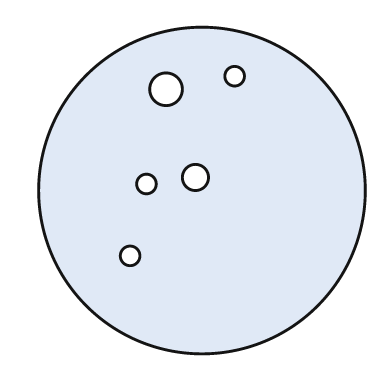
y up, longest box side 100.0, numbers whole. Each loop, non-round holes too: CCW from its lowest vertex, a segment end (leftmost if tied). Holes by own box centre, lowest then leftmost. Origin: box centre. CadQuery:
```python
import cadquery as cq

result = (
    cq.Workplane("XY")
    .moveTo(0.0, 0.0)
    .circle(50.0)
    .moveTo(-22.0, -20.0)
    .circle(3.0)
    .moveTo(-17.0, 2.0)
    .circle(3.0)
    .moveTo(-2.0, 4.0)
    .circle(4.0)
    .moveTo(-11.0, 31.0)
    .circle(5.0)
    .moveTo(10.0, 35.0)
    .circle(3.0)
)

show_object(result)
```